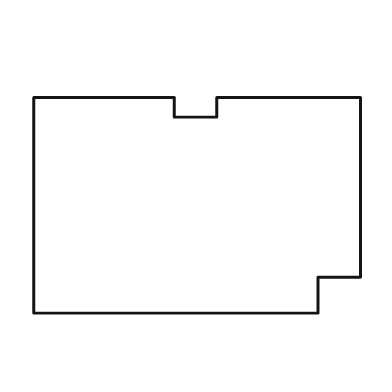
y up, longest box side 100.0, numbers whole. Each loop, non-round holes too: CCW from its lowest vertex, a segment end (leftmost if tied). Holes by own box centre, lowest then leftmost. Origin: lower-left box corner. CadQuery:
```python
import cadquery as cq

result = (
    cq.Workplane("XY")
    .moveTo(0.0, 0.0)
    .lineTo(87.0, 0.0)
    .lineTo(87.0, 11.0)
    .lineTo(100.0, 11.0)
    .lineTo(100.0, 66.0)
    .lineTo(56.0, 66.0)
    .lineTo(56.0, 60.0)
    .lineTo(43.0, 60.0)
    .lineTo(43.0, 66.0)
    .lineTo(0.0, 66.0)
    .close()
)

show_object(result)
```